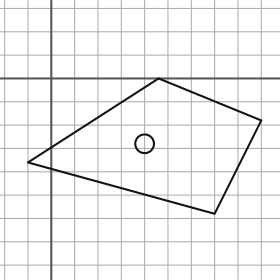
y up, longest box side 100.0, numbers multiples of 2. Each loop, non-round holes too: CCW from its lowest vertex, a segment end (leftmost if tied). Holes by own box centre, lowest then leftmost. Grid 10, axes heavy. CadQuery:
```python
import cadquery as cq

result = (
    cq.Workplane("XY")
    .moveTo(70.0, -58.0)
    .lineTo(90.0, -18.0)
    .lineTo(46.0, 0.0)
    .lineTo(-10.0, -36.0)
    .close()
    .moveTo(40.0, -28.0)
    .circle(4.0)
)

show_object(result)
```